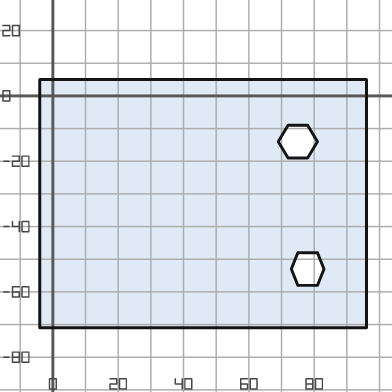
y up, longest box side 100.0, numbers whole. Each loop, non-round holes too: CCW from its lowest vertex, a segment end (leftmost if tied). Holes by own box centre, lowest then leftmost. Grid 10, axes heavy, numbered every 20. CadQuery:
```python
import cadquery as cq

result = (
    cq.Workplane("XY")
    .moveTo(-4.0, -71.0)
    .lineTo(96.0, -71.0)
    .lineTo(96.0, 5.0)
    .lineTo(-4.0, 5.0)
    .close()
    .moveTo(75.0, -58.0)
    .lineTo(81.0, -58.0)
    .lineTo(83.0, -53.0)
    .lineTo(81.0, -48.0)
    .lineTo(75.0, -48.0)
    .lineTo(73.0, -53.0)
    .close()
    .moveTo(72.0, -19.0)
    .lineTo(78.0, -19.0)
    .lineTo(81.0, -14.0)
    .lineTo(78.0, -9.0)
    .lineTo(72.0, -9.0)
    .lineTo(69.0, -14.0)
    .close()
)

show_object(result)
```